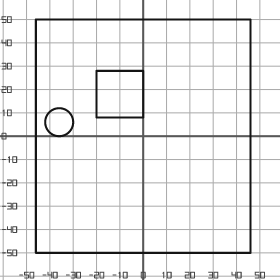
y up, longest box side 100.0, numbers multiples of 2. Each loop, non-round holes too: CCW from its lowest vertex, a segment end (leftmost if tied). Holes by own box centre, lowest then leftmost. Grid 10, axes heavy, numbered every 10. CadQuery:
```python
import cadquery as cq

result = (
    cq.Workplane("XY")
    .moveTo(-46.0, -50.0)
    .lineTo(46.0, -50.0)
    .lineTo(46.0, 50.0)
    .lineTo(-46.0, 50.0)
    .close()
    .moveTo(-36.0, 6.0)
    .circle(6.0)
    .moveTo(-20.0, 8.0)
    .lineTo(0.0, 8.0)
    .lineTo(0.0, 28.0)
    .lineTo(-20.0, 28.0)
    .close()
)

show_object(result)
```